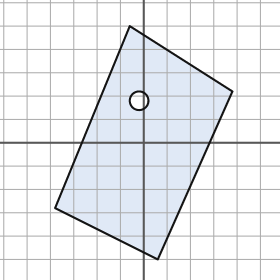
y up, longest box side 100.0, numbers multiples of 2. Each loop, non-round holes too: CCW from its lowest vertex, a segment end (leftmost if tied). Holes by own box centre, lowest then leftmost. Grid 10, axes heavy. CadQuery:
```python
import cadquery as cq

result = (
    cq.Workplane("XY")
    .moveTo(6.0, -50.0)
    .lineTo(38.0, 22.0)
    .lineTo(-6.0, 50.0)
    .lineTo(-38.0, -28.0)
    .close()
    .moveTo(-2.0, 18.0)
    .circle(4.0)
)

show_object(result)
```